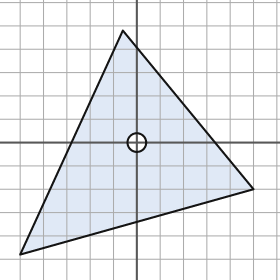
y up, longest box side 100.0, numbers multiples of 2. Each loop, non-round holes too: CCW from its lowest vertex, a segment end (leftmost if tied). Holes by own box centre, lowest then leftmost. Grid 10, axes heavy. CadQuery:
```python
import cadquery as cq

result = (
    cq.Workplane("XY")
    .moveTo(-50.0, -48.0)
    .lineTo(50.0, -20.0)
    .lineTo(-6.0, 48.0)
    .close()
    .moveTo(0.0, 0.0)
    .circle(4.0)
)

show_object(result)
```